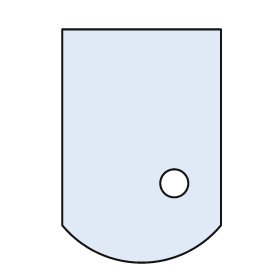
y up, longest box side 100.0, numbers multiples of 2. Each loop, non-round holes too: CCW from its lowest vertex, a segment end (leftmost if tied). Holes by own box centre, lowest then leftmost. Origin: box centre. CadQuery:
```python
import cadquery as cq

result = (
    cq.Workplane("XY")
    .moveTo(-34.0, -34.0)
    .threePointArc((0.0, -50.0), (34.0, -34.0))
    .lineTo(34.0, 50.0)
    .lineTo(-34.0, 50.0)
    .close()
    .moveTo(14.0, -16.0)
    .circle(6.0)
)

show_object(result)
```